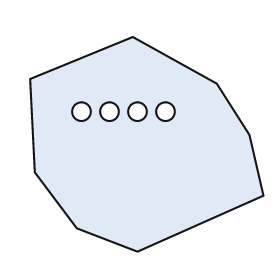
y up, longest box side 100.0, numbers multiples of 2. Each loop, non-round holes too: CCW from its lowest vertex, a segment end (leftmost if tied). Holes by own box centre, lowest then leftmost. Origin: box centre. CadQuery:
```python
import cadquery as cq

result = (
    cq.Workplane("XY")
    .moveTo(-4.0, -46.0)
    .lineTo(50.0, -22.0)
    .lineTo(44.0, 4.0)
    .lineTo(30.0, 26.0)
    .lineTo(-6.0, 46.0)
    .lineTo(-50.0, 28.0)
    .lineTo(-48.0, -12.0)
    .lineTo(-30.0, -36.0)
    .close()
    .moveTo(-28.0, 14.0)
    .circle(4.0)
    .moveTo(-16.0, 14.0)
    .circle(4.0)
    .moveTo(-4.0, 14.0)
    .circle(4.0)
    .moveTo(8.0, 14.0)
    .circle(4.0)
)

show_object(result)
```